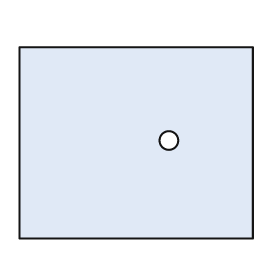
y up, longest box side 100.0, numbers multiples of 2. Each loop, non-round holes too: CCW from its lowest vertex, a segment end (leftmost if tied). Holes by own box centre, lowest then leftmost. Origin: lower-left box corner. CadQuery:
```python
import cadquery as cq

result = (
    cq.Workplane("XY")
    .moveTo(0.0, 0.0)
    .lineTo(100.0, 0.0)
    .lineTo(100.0, 82.0)
    .lineTo(0.0, 82.0)
    .close()
    .moveTo(64.0, 42.0)
    .circle(4.0)
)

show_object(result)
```